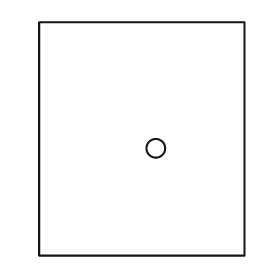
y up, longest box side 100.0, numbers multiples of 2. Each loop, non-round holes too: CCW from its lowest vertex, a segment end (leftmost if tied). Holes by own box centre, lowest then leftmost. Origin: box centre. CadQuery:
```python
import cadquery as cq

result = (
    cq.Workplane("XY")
    .moveTo(-44.0, -50.0)
    .lineTo(44.0, -50.0)
    .lineTo(44.0, 50.0)
    .lineTo(-44.0, 50.0)
    .close()
    .moveTo(6.0, -4.0)
    .circle(4.0)
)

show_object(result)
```